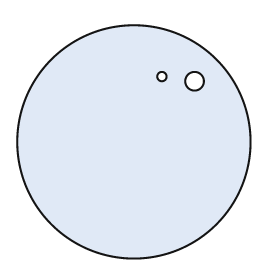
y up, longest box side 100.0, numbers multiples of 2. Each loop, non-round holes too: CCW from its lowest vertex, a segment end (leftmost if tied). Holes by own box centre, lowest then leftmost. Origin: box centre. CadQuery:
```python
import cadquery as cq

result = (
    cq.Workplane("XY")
    .moveTo(0.0, 0.0)
    .circle(50.0)
    .moveTo(26.0, 26.0)
    .circle(4.0)
    .moveTo(12.0, 28.0)
    .circle(2.0)
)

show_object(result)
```